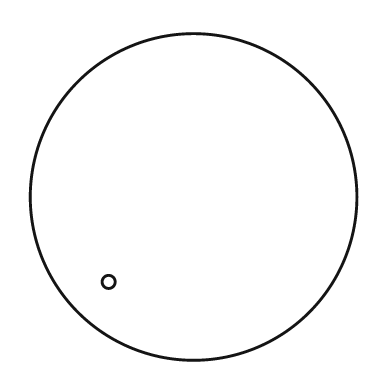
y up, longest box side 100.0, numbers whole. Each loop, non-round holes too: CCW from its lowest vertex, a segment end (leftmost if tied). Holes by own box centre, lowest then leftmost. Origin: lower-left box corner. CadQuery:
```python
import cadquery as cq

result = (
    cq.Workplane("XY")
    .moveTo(50.0, 50.0)
    .circle(50.0)
    .moveTo(24.0, 24.0)
    .circle(2.0)
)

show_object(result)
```